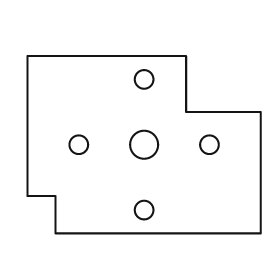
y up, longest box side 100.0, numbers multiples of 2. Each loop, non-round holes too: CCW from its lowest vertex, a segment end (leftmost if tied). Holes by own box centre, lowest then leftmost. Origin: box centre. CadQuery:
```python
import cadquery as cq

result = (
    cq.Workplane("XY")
    .moveTo(-38.0, -38.0)
    .lineTo(50.0, -38.0)
    .lineTo(50.0, 14.0)
    .lineTo(18.0, 14.0)
    .lineTo(18.0, 38.0)
    .lineTo(-50.0, 38.0)
    .lineTo(-50.0, -22.0)
    .lineTo(-38.0, -22.0)
    .close()
    .moveTo(0.0, -28.0)
    .circle(4.0)
    .moveTo(-28.0, 0.0)
    .circle(4.0)
    .moveTo(0.0, 0.0)
    .circle(6.0)
    .moveTo(28.0, 0.0)
    .circle(4.0)
    .moveTo(0.0, 28.0)
    .circle(4.0)
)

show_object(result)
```